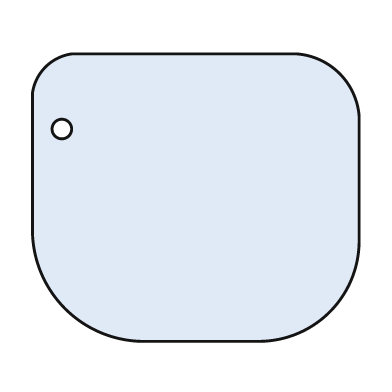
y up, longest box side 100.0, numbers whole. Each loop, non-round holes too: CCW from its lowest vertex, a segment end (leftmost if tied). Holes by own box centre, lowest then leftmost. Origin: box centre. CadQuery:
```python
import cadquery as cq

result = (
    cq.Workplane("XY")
    .moveTo(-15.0, -44.0)
    .lineTo(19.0, -44.0)
    .threePointArc((41.0, -35.0), (50.0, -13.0))
    .lineTo(50.0, 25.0)
    .threePointArc((44.0, 38.0), (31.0, 44.0))
    .lineTo(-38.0, 44.0)
    .threePointArc((-46.0, 40.0), (-50.0, 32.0))
    .lineTo(-50.0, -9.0)
    .threePointArc((-40.0, -34.0), (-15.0, -44.0))
    .close()
    .moveTo(-41.0, 21.0)
    .circle(3.0)
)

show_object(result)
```